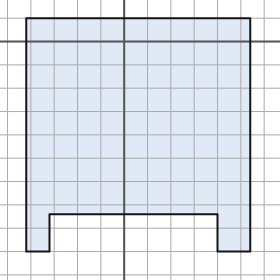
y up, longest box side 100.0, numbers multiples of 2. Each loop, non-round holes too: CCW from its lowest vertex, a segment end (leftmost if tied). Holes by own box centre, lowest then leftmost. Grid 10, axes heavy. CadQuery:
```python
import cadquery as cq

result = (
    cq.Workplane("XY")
    .moveTo(-42.0, -90.0)
    .lineTo(-32.0, -90.0)
    .lineTo(-32.0, -74.0)
    .lineTo(40.0, -74.0)
    .lineTo(40.0, -90.0)
    .lineTo(54.0, -90.0)
    .lineTo(54.0, 10.0)
    .lineTo(-42.0, 10.0)
    .close()
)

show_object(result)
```